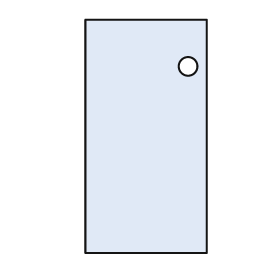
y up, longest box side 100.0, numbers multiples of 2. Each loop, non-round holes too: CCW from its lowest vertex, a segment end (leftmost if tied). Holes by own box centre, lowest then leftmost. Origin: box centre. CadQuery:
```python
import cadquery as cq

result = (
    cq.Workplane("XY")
    .moveTo(-26.0, -50.0)
    .lineTo(26.0, -50.0)
    .lineTo(26.0, 50.0)
    .lineTo(-26.0, 50.0)
    .close()
    .moveTo(18.0, 30.0)
    .circle(4.0)
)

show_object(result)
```